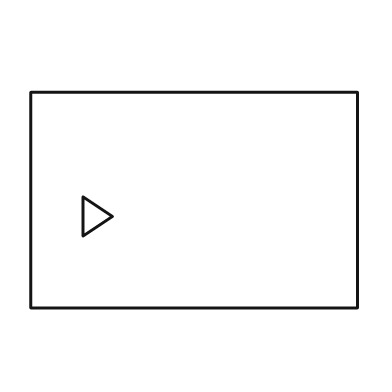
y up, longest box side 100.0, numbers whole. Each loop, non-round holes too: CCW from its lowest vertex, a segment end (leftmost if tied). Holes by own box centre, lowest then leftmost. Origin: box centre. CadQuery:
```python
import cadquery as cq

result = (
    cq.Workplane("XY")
    .moveTo(-50.0, -33.0)
    .lineTo(50.0, -33.0)
    .lineTo(50.0, 33.0)
    .lineTo(-50.0, 33.0)
    .close()
    .moveTo(-34.0, -11.0)
    .lineTo(-25.0, -5.0)
    .lineTo(-34.0, 1.0)
    .close()
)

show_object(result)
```